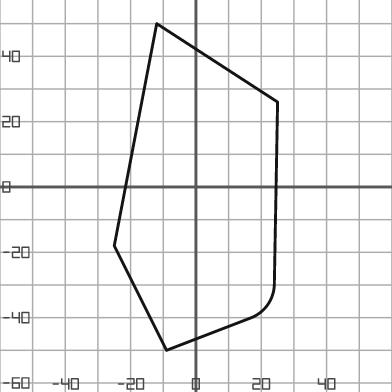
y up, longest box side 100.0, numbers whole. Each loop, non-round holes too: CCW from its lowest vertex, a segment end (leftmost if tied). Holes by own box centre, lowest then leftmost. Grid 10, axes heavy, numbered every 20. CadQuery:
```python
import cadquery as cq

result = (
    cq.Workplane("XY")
    .moveTo(-9.0, -50.0)
    .lineTo(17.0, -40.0)
    .threePointArc((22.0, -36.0), (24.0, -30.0))
    .lineTo(25.0, 26.0)
    .lineTo(-12.0, 50.0)
    .lineTo(-25.0, -18.0)
    .close()
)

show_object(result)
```